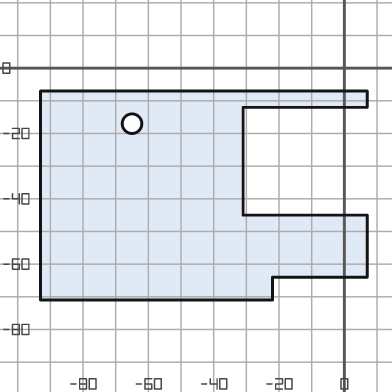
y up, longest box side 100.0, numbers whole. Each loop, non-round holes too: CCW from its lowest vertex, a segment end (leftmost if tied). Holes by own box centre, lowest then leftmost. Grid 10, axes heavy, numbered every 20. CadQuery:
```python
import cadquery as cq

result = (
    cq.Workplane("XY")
    .moveTo(-93.0, -71.0)
    .lineTo(-22.0, -71.0)
    .lineTo(-22.0, -64.0)
    .lineTo(7.0, -64.0)
    .lineTo(7.0, -45.0)
    .lineTo(-31.0, -45.0)
    .lineTo(-31.0, -12.0)
    .lineTo(7.0, -12.0)
    .lineTo(7.0, -7.0)
    .lineTo(-93.0, -7.0)
    .close()
    .moveTo(-65.0, -17.0)
    .circle(3.0)
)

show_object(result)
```